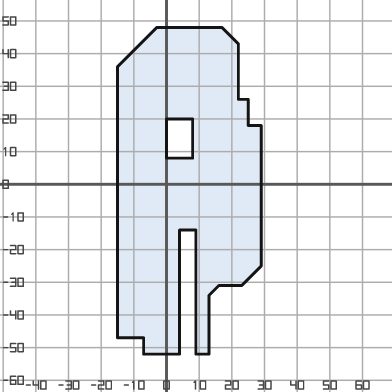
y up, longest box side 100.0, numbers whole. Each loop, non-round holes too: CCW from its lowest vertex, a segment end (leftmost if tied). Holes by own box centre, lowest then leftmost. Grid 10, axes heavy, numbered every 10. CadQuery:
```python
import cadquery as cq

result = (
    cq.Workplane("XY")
    .moveTo(-7.0, -52.0)
    .lineTo(4.0, -52.0)
    .lineTo(4.0, -14.0)
    .lineTo(9.0, -14.0)
    .lineTo(9.0, -52.0)
    .lineTo(13.0, -52.0)
    .lineTo(13.0, -34.0)
    .lineTo(16.0, -31.0)
    .lineTo(23.0, -31.0)
    .lineTo(29.0, -25.0)
    .lineTo(29.0, 18.0)
    .lineTo(25.0, 18.0)
    .lineTo(25.0, 26.0)
    .lineTo(22.0, 26.0)
    .lineTo(22.0, 43.0)
    .lineTo(17.0, 48.0)
    .lineTo(-3.0, 48.0)
    .lineTo(-15.0, 36.0)
    .lineTo(-15.0, -47.0)
    .lineTo(-7.0, -47.0)
    .close()
    .moveTo(0.0, 8.0)
    .lineTo(8.0, 8.0)
    .lineTo(8.0, 20.0)
    .lineTo(0.0, 20.0)
    .close()
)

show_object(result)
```